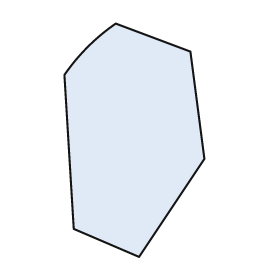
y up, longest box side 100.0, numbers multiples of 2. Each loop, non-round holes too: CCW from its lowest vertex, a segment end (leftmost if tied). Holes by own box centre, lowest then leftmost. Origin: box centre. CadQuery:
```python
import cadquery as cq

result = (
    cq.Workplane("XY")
    .moveTo(2.0, -50.0)
    .lineTo(30.0, -8.0)
    .lineTo(24.0, 38.0)
    .lineTo(-8.0, 50.0)
    .threePointArc((-20.0, 40.0), (-30.0, 28.0))
    .lineTo(-26.0, -38.0)
    .close()
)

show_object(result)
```